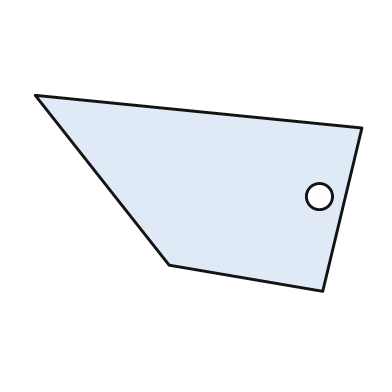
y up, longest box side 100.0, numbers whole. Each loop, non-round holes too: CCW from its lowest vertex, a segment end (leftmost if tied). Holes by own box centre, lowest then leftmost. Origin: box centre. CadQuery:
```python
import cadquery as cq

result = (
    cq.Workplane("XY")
    .moveTo(38.0, -30.0)
    .lineTo(50.0, 20.0)
    .lineTo(-50.0, 30.0)
    .lineTo(-9.0, -22.0)
    .close()
    .moveTo(37.0, -1.0)
    .circle(4.0)
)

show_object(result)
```